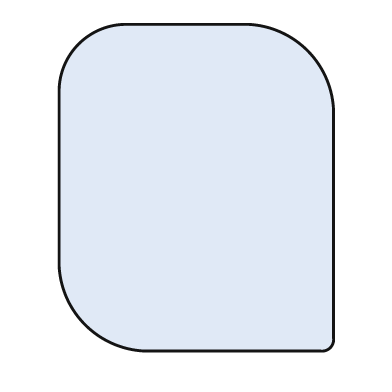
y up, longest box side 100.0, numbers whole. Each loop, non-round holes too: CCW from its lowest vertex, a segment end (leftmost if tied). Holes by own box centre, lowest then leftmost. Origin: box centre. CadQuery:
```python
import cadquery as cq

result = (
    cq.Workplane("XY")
    .moveTo(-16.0, -50.0)
    .lineTo(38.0, -50.0)
    .threePointArc((41.0, -49.0), (42.0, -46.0))
    .lineTo(42.0, 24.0)
    .threePointArc((34.0, 42.0), (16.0, 50.0))
    .lineTo(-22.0, 50.0)
    .threePointArc((-36.0, 44.0), (-42.0, 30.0))
    .lineTo(-42.0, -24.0)
    .threePointArc((-34.0, -42.0), (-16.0, -50.0))
    .close()
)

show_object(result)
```